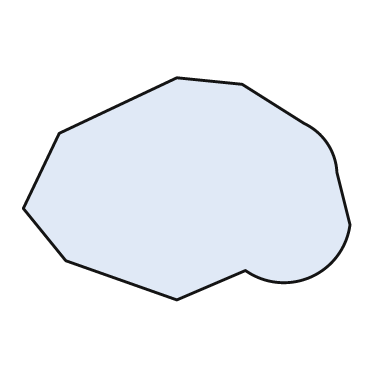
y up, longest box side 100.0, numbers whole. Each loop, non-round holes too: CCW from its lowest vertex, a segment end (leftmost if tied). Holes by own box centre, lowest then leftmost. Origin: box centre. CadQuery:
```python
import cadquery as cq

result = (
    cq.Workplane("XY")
    .moveTo(-3.0, -34.0)
    .lineTo(18.0, -25.0)
    .threePointArc((38.0, -27.0), (50.0, -11.0))
    .lineTo(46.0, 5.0)
    .threePointArc((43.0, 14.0), (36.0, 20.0))
    .lineTo(17.0, 32.0)
    .lineTo(-3.0, 34.0)
    .lineTo(-39.0, 17.0)
    .lineTo(-50.0, -6.0)
    .lineTo(-37.0, -22.0)
    .close()
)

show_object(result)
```